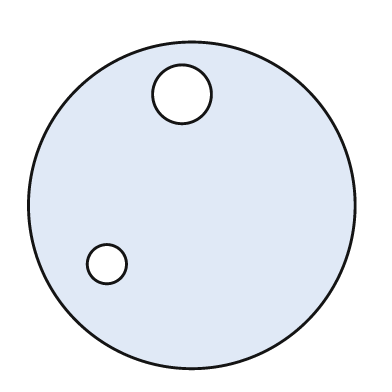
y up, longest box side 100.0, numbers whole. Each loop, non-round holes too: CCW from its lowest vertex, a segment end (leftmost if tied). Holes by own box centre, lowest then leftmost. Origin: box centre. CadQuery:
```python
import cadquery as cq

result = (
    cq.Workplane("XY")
    .moveTo(0.0, 0.0)
    .circle(50.0)
    .moveTo(-26.0, -18.0)
    .circle(6.0)
    .moveTo(-3.0, 34.0)
    .circle(9.0)
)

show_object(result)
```